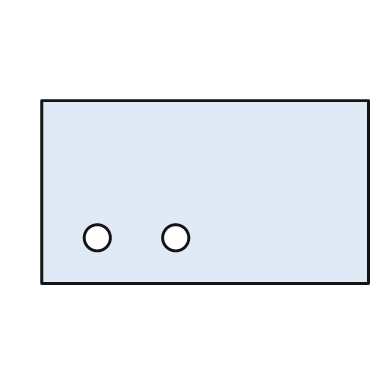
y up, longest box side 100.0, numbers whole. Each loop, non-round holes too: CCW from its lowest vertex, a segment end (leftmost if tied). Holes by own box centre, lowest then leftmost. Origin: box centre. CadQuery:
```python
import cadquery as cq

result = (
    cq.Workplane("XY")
    .moveTo(-50.0, -28.0)
    .lineTo(50.0, -28.0)
    .lineTo(50.0, 28.0)
    .lineTo(-50.0, 28.0)
    .close()
    .moveTo(-33.0, -14.0)
    .circle(4.0)
    .moveTo(-9.0, -14.0)
    .circle(4.0)
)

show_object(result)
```